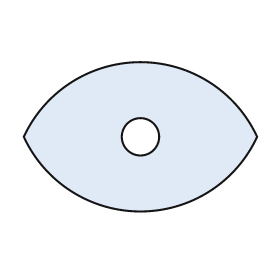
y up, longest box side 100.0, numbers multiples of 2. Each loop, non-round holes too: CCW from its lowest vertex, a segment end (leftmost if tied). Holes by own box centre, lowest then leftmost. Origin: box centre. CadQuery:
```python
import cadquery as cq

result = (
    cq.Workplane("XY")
    .moveTo(-50.0, 0.0)
    .threePointArc((0.0, -32.0), (50.0, 0.0))
    .threePointArc((0.0, 32.0), (-50.0, 0.0))
    .close()
    .moveTo(0.0, 0.0)
    .circle(8.0)
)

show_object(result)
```